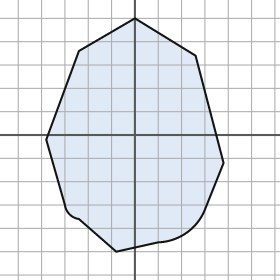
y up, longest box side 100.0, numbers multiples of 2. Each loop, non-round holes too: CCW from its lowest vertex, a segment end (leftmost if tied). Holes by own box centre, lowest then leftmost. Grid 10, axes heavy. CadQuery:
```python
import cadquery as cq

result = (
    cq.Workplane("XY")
    .moveTo(-8.0, -50.0)
    .lineTo(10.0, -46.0)
    .threePointArc((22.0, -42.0), (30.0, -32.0))
    .lineTo(38.0, -12.0)
    .lineTo(26.0, 34.0)
    .lineTo(0.0, 50.0)
    .lineTo(-24.0, 36.0)
    .lineTo(-38.0, -2.0)
    .lineTo(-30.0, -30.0)
    .threePointArc((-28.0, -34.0), (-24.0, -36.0))
    .close()
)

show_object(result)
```